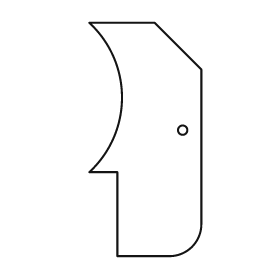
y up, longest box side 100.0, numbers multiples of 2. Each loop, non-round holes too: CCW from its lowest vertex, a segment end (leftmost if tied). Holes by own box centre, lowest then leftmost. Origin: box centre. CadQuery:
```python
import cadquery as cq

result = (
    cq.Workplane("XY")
    .moveTo(-12.0, -50.0)
    .lineTo(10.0, -50.0)
    .threePointArc((20.0, -46.0), (24.0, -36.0))
    .lineTo(24.0, 30.0)
    .lineTo(4.0, 50.0)
    .lineTo(-24.0, 50.0)
    .threePointArc((-10.0, 18.0), (-24.0, -14.0))
    .lineTo(-12.0, -14.0)
    .close()
    .moveTo(16.0, 4.0)
    .circle(2.0)
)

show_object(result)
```